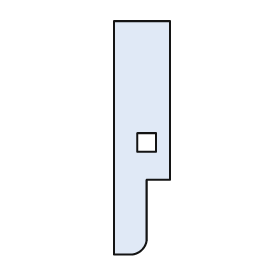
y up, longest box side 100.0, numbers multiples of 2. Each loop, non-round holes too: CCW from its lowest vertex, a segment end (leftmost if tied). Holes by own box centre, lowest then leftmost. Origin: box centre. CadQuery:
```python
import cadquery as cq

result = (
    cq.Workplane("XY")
    .moveTo(-12.0, -50.0)
    .lineTo(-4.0, -50.0)
    .threePointArc((0.0, -48.0), (2.0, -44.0))
    .lineTo(2.0, -18.0)
    .lineTo(12.0, -18.0)
    .lineTo(12.0, 50.0)
    .lineTo(-12.0, 50.0)
    .close()
    .moveTo(-2.0, -6.0)
    .lineTo(6.0, -6.0)
    .lineTo(6.0, 2.0)
    .lineTo(-2.0, 2.0)
    .close()
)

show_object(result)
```